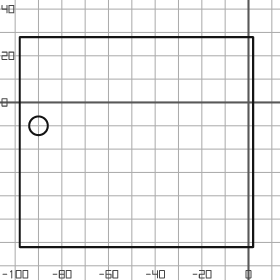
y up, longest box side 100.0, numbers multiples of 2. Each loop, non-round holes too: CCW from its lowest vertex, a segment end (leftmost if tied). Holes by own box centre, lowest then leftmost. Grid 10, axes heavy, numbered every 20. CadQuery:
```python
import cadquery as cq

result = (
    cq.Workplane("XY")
    .moveTo(-98.0, -62.0)
    .lineTo(2.0, -62.0)
    .lineTo(2.0, 28.0)
    .lineTo(-98.0, 28.0)
    .close()
    .moveTo(-90.0, -10.0)
    .circle(4.0)
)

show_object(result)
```